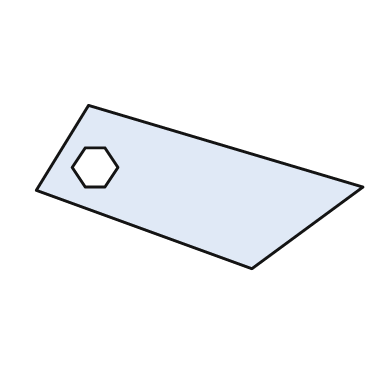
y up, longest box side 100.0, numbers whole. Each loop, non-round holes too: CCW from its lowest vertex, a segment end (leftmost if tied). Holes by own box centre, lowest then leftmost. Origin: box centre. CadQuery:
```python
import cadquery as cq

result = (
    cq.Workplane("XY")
    .moveTo(16.0, -25.0)
    .lineTo(50.0, 0.0)
    .lineTo(-34.0, 25.0)
    .lineTo(-50.0, -1.0)
    .close()
    .moveTo(-35.0, 0.0)
    .lineTo(-29.0, 0.0)
    .lineTo(-25.0, 6.0)
    .lineTo(-29.0, 12.0)
    .lineTo(-35.0, 12.0)
    .lineTo(-39.0, 6.0)
    .close()
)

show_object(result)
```